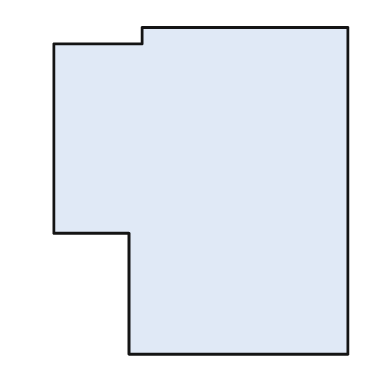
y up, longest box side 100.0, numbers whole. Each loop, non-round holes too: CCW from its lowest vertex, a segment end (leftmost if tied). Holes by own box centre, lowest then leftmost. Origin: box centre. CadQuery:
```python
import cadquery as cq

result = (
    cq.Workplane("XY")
    .moveTo(-22.0, -50.0)
    .lineTo(45.0, -50.0)
    .lineTo(45.0, 50.0)
    .lineTo(-18.0, 50.0)
    .lineTo(-18.0, 45.0)
    .lineTo(-45.0, 45.0)
    .lineTo(-45.0, -13.0)
    .lineTo(-22.0, -13.0)
    .close()
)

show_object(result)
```